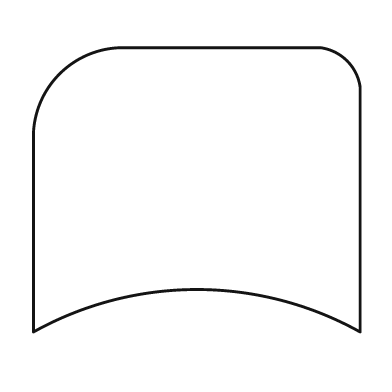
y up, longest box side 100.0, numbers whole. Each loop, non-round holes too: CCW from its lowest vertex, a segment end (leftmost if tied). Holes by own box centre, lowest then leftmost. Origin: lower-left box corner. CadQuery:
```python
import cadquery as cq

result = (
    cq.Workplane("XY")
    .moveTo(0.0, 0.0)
    .threePointArc((50.0, 13.0), (100.0, 0.0))
    .lineTo(100.0, 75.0)
    .threePointArc((96.0, 83.0), (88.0, 87.0))
    .lineTo(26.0, 87.0)
    .threePointArc((8.0, 79.0), (0.0, 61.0))
    .close()
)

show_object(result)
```